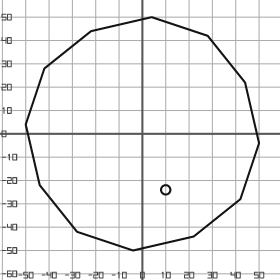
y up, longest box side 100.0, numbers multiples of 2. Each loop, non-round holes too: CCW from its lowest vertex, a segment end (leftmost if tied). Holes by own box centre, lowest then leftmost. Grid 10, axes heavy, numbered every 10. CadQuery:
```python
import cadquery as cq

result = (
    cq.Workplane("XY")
    .moveTo(-4.0, -50.0)
    .lineTo(22.0, -44.0)
    .lineTo(42.0, -28.0)
    .lineTo(50.0, -4.0)
    .lineTo(44.0, 22.0)
    .lineTo(28.0, 42.0)
    .lineTo(4.0, 50.0)
    .lineTo(-22.0, 44.0)
    .lineTo(-42.0, 28.0)
    .lineTo(-50.0, 4.0)
    .lineTo(-44.0, -22.0)
    .lineTo(-28.0, -42.0)
    .close()
    .moveTo(10.0, -24.0)
    .circle(2.0)
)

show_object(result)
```